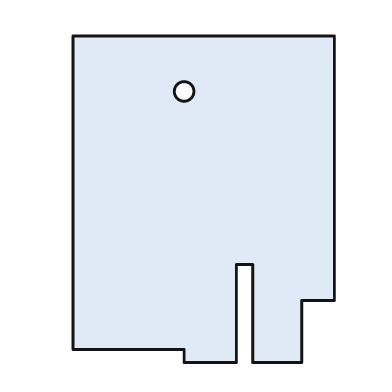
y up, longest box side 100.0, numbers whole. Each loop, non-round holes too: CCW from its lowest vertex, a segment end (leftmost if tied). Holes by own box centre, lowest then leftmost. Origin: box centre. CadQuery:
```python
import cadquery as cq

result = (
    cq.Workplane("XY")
    .moveTo(-6.0, -50.0)
    .lineTo(10.0, -50.0)
    .lineTo(10.0, -20.0)
    .lineTo(15.0, -20.0)
    .lineTo(15.0, -50.0)
    .lineTo(30.0, -50.0)
    .lineTo(30.0, -31.0)
    .lineTo(40.0, -31.0)
    .lineTo(40.0, 50.0)
    .lineTo(-40.0, 50.0)
    .lineTo(-40.0, -46.0)
    .lineTo(-6.0, -46.0)
    .close()
    .moveTo(-6.0, 33.0)
    .circle(3.0)
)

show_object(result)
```